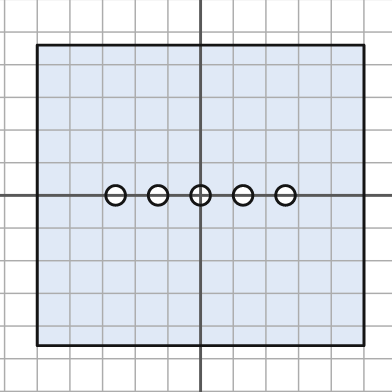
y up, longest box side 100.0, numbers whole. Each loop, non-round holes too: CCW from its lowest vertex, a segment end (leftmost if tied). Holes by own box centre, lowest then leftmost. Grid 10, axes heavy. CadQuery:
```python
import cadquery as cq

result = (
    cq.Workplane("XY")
    .moveTo(-50.0, -46.0)
    .lineTo(50.0, -46.0)
    .lineTo(50.0, 46.0)
    .lineTo(-50.0, 46.0)
    .close()
    .moveTo(-26.0, 0.0)
    .circle(3.0)
    .moveTo(-13.0, 0.0)
    .circle(3.0)
    .moveTo(0.0, 0.0)
    .circle(3.0)
    .moveTo(13.0, 0.0)
    .circle(3.0)
    .moveTo(26.0, 0.0)
    .circle(3.0)
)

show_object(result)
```